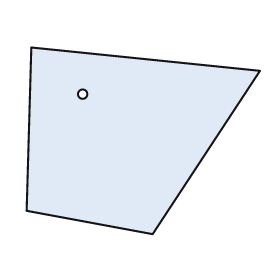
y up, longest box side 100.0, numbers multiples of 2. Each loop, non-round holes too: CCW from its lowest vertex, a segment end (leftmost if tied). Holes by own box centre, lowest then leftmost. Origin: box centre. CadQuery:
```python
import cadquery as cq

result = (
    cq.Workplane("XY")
    .moveTo(4.0, -40.0)
    .lineTo(50.0, 30.0)
    .lineTo(-48.0, 40.0)
    .lineTo(-50.0, -30.0)
    .close()
    .moveTo(-26.0, 20.0)
    .circle(2.0)
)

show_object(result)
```